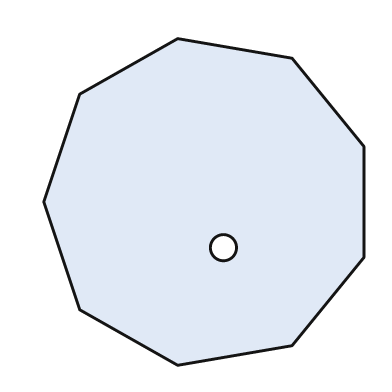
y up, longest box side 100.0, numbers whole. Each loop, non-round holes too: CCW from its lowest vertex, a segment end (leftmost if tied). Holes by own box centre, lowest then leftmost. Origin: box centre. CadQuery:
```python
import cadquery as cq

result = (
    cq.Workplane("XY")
    .moveTo(-8.0, -50.0)
    .lineTo(27.0, -44.0)
    .lineTo(49.0, -17.0)
    .lineTo(49.0, 17.0)
    .lineTo(27.0, 44.0)
    .lineTo(-8.0, 50.0)
    .lineTo(-38.0, 33.0)
    .lineTo(-49.0, 0.0)
    .lineTo(-38.0, -33.0)
    .close()
    .moveTo(6.0, -14.0)
    .circle(4.0)
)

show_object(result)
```